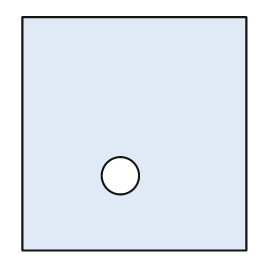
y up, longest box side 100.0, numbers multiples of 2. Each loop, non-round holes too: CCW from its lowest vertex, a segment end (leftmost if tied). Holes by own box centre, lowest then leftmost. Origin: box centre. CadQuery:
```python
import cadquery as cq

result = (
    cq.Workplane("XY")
    .moveTo(-48.0, -50.0)
    .lineTo(48.0, -50.0)
    .lineTo(48.0, 50.0)
    .lineTo(-48.0, 50.0)
    .close()
    .moveTo(-6.0, -18.0)
    .circle(8.0)
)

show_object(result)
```